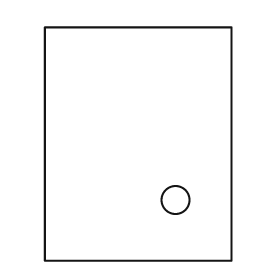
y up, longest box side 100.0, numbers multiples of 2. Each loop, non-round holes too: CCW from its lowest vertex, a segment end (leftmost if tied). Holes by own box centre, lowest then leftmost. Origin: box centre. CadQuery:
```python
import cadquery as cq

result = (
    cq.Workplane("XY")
    .moveTo(-40.0, -50.0)
    .lineTo(40.0, -50.0)
    .lineTo(40.0, 50.0)
    .lineTo(-40.0, 50.0)
    .close()
    .moveTo(16.0, -24.0)
    .circle(6.0)
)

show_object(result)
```